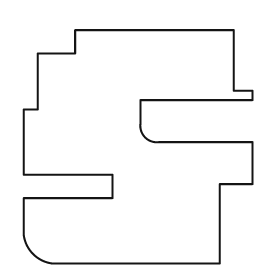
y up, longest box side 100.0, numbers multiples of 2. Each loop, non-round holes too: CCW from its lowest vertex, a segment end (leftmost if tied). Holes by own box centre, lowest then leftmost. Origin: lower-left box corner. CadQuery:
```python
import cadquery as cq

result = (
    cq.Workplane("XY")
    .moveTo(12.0, 0.0)
    .lineTo(84.0, 0.0)
    .lineTo(84.0, 34.0)
    .lineTo(98.0, 34.0)
    .lineTo(98.0, 52.0)
    .lineTo(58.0, 52.0)
    .threePointArc((52.0, 54.0), (50.0, 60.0))
    .lineTo(50.0, 70.0)
    .lineTo(98.0, 70.0)
    .lineTo(98.0, 74.0)
    .lineTo(90.0, 74.0)
    .lineTo(90.0, 100.0)
    .lineTo(22.0, 100.0)
    .lineTo(22.0, 90.0)
    .lineTo(6.0, 90.0)
    .lineTo(6.0, 66.0)
    .lineTo(0.0, 66.0)
    .lineTo(0.0, 38.0)
    .lineTo(38.0, 38.0)
    .lineTo(38.0, 28.0)
    .lineTo(0.0, 28.0)
    .lineTo(0.0, 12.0)
    .threePointArc((4.0, 4.0), (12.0, 0.0))
    .close()
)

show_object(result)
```